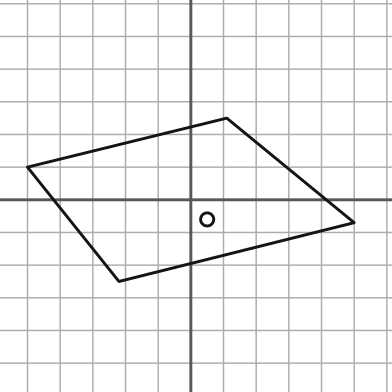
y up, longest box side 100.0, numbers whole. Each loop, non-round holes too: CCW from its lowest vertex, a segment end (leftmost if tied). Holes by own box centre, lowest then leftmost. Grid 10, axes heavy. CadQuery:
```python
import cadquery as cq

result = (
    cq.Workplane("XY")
    .moveTo(-22.0, -25.0)
    .lineTo(50.0, -7.0)
    .lineTo(11.0, 25.0)
    .lineTo(-50.0, 10.0)
    .close()
    .moveTo(5.0, -6.0)
    .circle(2.0)
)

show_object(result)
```